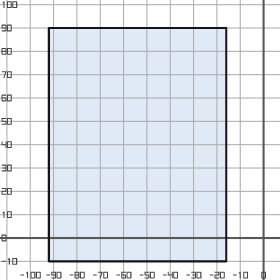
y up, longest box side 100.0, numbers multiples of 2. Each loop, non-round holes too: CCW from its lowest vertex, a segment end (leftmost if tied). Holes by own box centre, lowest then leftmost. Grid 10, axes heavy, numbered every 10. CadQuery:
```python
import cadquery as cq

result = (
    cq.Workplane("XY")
    .moveTo(-92.0, -10.0)
    .lineTo(-16.0, -10.0)
    .lineTo(-16.0, 90.0)
    .lineTo(-92.0, 90.0)
    .close()
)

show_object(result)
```